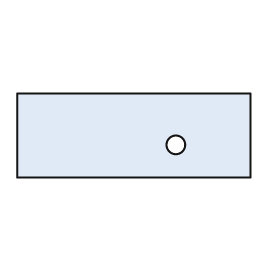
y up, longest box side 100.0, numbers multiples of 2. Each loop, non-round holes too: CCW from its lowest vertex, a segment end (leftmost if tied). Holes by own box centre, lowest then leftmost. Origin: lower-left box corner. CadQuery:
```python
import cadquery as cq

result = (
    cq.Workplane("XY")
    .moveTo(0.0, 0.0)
    .lineTo(100.0, 0.0)
    .lineTo(100.0, 36.0)
    .lineTo(0.0, 36.0)
    .close()
    .moveTo(68.0, 14.0)
    .circle(4.0)
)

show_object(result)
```